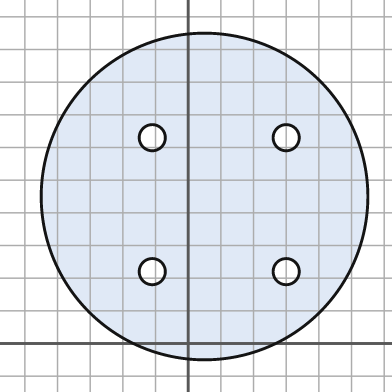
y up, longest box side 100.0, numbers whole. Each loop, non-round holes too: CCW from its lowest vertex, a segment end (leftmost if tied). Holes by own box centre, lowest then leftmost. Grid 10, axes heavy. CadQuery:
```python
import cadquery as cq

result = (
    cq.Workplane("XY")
    .moveTo(5.0, 45.0)
    .circle(50.0)
    .moveTo(-11.0, 22.0)
    .circle(4.0)
    .moveTo(30.0, 22.0)
    .circle(4.0)
    .moveTo(-11.0, 63.0)
    .circle(4.0)
    .moveTo(30.0, 63.0)
    .circle(4.0)
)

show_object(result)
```